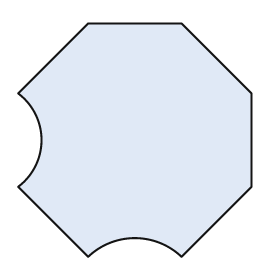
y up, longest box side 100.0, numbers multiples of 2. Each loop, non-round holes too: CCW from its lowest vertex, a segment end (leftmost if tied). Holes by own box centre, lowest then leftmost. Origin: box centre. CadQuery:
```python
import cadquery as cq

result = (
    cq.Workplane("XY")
    .moveTo(-20.0, -50.0)
    .threePointArc((0.0, -42.0), (20.0, -50.0))
    .lineTo(50.0, -20.0)
    .lineTo(50.0, 20.0)
    .lineTo(20.0, 50.0)
    .lineTo(-20.0, 50.0)
    .lineTo(-50.0, 20.0)
    .threePointArc((-40.0, 0.0), (-50.0, -20.0))
    .close()
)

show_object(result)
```